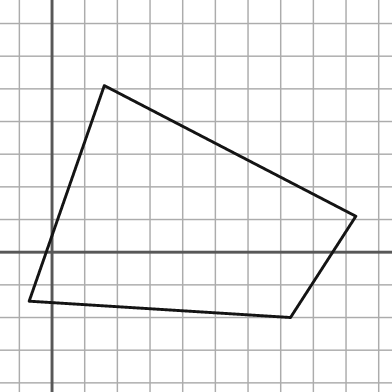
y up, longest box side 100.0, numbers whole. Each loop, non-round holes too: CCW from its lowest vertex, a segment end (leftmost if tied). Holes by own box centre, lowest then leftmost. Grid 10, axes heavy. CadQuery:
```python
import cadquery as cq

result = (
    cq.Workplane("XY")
    .moveTo(73.0, -20.0)
    .lineTo(93.0, 11.0)
    .lineTo(16.0, 51.0)
    .lineTo(-7.0, -15.0)
    .close()
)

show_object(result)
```